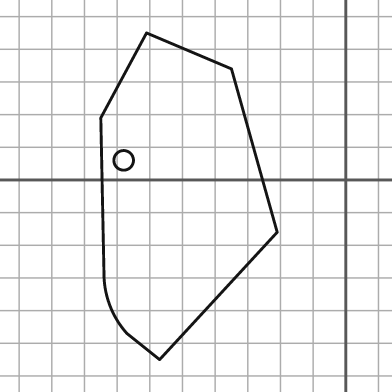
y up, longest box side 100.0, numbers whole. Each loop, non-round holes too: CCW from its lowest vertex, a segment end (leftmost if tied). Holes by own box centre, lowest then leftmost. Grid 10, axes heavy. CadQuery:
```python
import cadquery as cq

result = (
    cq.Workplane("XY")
    .moveTo(-57.0, -55.0)
    .lineTo(-21.0, -16.0)
    .lineTo(-35.0, 34.0)
    .lineTo(-61.0, 45.0)
    .lineTo(-75.0, 19.0)
    .lineTo(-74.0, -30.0)
    .threePointArc((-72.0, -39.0), (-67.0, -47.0))
    .close()
    .moveTo(-68.0, 6.0)
    .circle(3.0)
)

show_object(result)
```